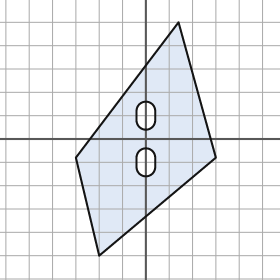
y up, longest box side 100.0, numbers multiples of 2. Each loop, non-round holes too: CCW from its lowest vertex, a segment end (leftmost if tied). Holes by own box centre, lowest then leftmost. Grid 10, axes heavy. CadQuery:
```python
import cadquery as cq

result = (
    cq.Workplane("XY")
    .moveTo(-20.0, -50.0)
    .lineTo(30.0, -8.0)
    .lineTo(14.0, 50.0)
    .lineTo(-30.0, -8.0)
    .close()
    .moveTo(-4.0, -12.0)
    .threePointArc((0.0, -16.0), (4.0, -12.0))
    .lineTo(4.0, -8.0)
    .threePointArc((0.0, -4.0), (-4.0, -8.0))
    .close()
    .moveTo(-4.0, 8.0)
    .threePointArc((0.0, 4.0), (4.0, 8.0))
    .lineTo(4.0, 12.0)
    .threePointArc((0.0, 16.0), (-4.0, 12.0))
    .close()
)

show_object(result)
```